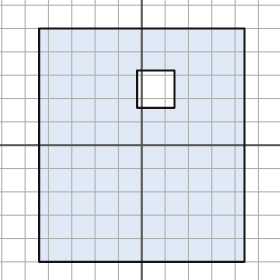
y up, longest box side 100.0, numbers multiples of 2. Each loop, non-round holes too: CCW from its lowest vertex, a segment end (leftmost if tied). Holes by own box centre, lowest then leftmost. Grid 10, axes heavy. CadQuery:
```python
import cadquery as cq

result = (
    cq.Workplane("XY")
    .moveTo(-44.0, -50.0)
    .lineTo(44.0, -50.0)
    .lineTo(44.0, 50.0)
    .lineTo(-44.0, 50.0)
    .close()
    .moveTo(-2.0, 16.0)
    .lineTo(14.0, 16.0)
    .lineTo(14.0, 32.0)
    .lineTo(-2.0, 32.0)
    .close()
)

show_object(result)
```